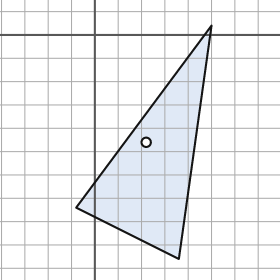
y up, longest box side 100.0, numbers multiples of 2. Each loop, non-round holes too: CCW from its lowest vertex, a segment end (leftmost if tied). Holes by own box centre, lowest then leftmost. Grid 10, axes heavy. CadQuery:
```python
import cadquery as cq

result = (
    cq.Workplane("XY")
    .moveTo(36.0, -96.0)
    .lineTo(50.0, 4.0)
    .lineTo(-8.0, -74.0)
    .close()
    .moveTo(22.0, -46.0)
    .circle(2.0)
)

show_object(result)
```